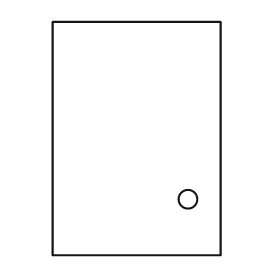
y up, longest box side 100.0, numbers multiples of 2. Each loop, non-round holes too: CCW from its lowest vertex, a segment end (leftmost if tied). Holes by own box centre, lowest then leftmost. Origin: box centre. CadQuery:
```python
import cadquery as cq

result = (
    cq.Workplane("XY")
    .moveTo(-36.0, -50.0)
    .lineTo(36.0, -50.0)
    .lineTo(36.0, 50.0)
    .lineTo(-36.0, 50.0)
    .close()
    .moveTo(22.0, -26.0)
    .circle(4.0)
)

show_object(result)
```